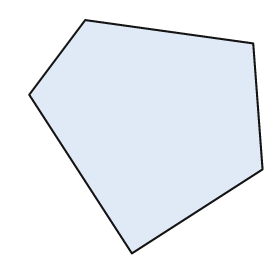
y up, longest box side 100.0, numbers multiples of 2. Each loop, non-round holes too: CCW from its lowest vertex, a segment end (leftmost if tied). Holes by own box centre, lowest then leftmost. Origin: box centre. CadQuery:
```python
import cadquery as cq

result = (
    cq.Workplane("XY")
    .moveTo(-6.0, -50.0)
    .lineTo(50.0, -14.0)
    .lineTo(46.0, 40.0)
    .lineTo(-26.0, 50.0)
    .lineTo(-50.0, 18.0)
    .close()
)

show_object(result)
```